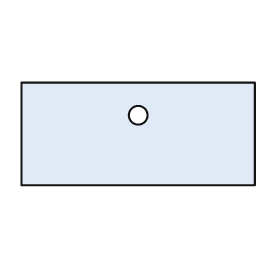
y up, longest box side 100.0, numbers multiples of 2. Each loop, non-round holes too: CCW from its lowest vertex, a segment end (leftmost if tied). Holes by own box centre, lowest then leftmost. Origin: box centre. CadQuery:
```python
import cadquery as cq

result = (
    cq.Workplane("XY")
    .moveTo(-50.0, -22.0)
    .lineTo(50.0, -22.0)
    .lineTo(50.0, 22.0)
    .lineTo(-50.0, 22.0)
    .close()
    .moveTo(0.0, 8.0)
    .circle(4.0)
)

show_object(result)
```